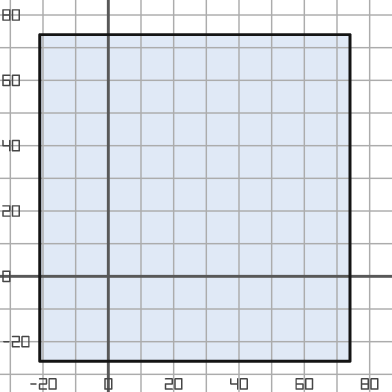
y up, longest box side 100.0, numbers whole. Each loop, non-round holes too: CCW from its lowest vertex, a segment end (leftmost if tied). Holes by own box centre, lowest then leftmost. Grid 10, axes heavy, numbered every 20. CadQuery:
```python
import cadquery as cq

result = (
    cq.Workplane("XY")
    .moveTo(-21.0, -26.0)
    .lineTo(74.0, -26.0)
    .lineTo(74.0, 74.0)
    .lineTo(-21.0, 74.0)
    .close()
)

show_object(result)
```